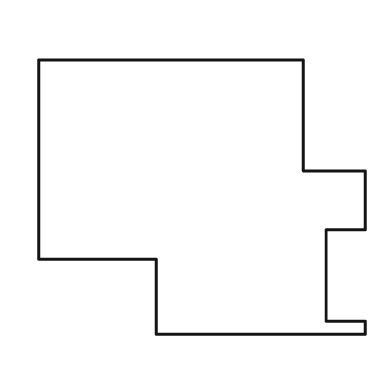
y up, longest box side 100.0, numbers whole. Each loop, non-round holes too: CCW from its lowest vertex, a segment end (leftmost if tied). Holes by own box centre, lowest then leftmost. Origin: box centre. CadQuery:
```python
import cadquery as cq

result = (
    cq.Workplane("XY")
    .moveTo(-14.0, -42.0)
    .lineTo(50.0, -42.0)
    .lineTo(50.0, -38.0)
    .lineTo(38.0, -38.0)
    .lineTo(38.0, -10.0)
    .lineTo(50.0, -10.0)
    .lineTo(50.0, 8.0)
    .lineTo(31.0, 8.0)
    .lineTo(31.0, 42.0)
    .lineTo(-50.0, 42.0)
    .lineTo(-50.0, -19.0)
    .lineTo(-14.0, -19.0)
    .close()
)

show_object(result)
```